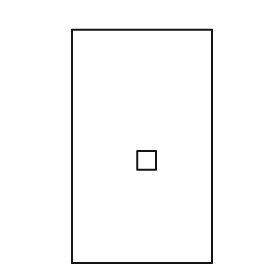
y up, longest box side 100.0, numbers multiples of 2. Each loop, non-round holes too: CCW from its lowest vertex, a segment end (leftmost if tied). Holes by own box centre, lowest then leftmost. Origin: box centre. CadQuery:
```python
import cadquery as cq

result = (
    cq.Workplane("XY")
    .moveTo(-30.0, -50.0)
    .lineTo(30.0, -50.0)
    .lineTo(30.0, 50.0)
    .lineTo(-30.0, 50.0)
    .close()
    .moveTo(-2.0, -10.0)
    .lineTo(6.0, -10.0)
    .lineTo(6.0, -2.0)
    .lineTo(-2.0, -2.0)
    .close()
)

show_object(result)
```